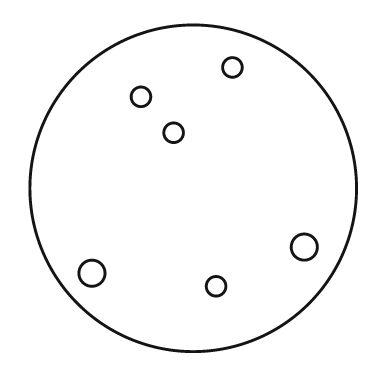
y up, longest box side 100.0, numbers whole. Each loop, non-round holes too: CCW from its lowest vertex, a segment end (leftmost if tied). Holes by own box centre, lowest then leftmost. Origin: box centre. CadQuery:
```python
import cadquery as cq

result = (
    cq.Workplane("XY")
    .moveTo(0.0, 0.0)
    .circle(50.0)
    .moveTo(7.0, -30.0)
    .circle(3.0)
    .moveTo(-31.0, -26.0)
    .circle(4.0)
    .moveTo(34.0, -18.0)
    .circle(4.0)
    .moveTo(-6.0, 17.0)
    .circle(3.0)
    .moveTo(-16.0, 28.0)
    .circle(3.0)
    .moveTo(12.0, 37.0)
    .circle(3.0)
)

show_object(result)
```